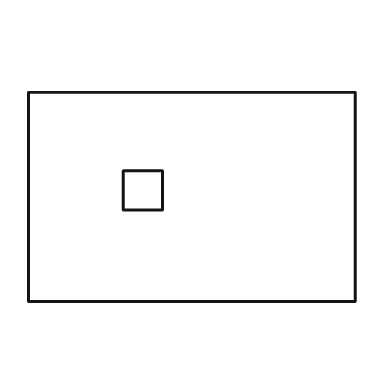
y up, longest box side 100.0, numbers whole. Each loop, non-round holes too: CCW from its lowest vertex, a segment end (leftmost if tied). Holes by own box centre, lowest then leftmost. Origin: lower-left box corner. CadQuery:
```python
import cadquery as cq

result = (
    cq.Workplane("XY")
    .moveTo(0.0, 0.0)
    .lineTo(100.0, 0.0)
    .lineTo(100.0, 64.0)
    .lineTo(0.0, 64.0)
    .close()
    .moveTo(29.0, 28.0)
    .lineTo(41.0, 28.0)
    .lineTo(41.0, 40.0)
    .lineTo(29.0, 40.0)
    .close()
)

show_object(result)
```